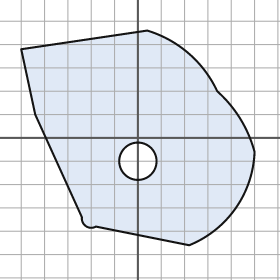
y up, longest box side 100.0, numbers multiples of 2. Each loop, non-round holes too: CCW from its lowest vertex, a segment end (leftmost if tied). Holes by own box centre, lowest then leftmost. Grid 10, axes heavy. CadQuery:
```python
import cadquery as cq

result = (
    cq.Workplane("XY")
    .moveTo(22.0, -46.0)
    .threePointArc((42.0, -30.0), (50.0, -6.0))
    .threePointArc((44.0, 8.0), (34.0, 20.0))
    .threePointArc((22.0, 36.0), (4.0, 46.0))
    .lineTo(-50.0, 38.0)
    .lineTo(-44.0, 10.0)
    .lineTo(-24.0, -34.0)
    .threePointArc((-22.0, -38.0), (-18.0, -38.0))
    .close()
    .moveTo(0.0, -10.0)
    .circle(8.0)
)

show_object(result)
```